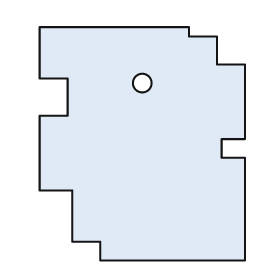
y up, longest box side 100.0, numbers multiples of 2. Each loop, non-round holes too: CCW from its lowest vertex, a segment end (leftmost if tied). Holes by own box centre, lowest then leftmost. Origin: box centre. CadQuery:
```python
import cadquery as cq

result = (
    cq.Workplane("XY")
    .moveTo(-18.0, -50.0)
    .lineTo(44.0, -50.0)
    .lineTo(44.0, -6.0)
    .lineTo(34.0, -6.0)
    .lineTo(34.0, 2.0)
    .lineTo(44.0, 2.0)
    .lineTo(44.0, 34.0)
    .lineTo(32.0, 34.0)
    .lineTo(32.0, 46.0)
    .lineTo(20.0, 46.0)
    .lineTo(20.0, 50.0)
    .lineTo(-44.0, 50.0)
    .lineTo(-44.0, 28.0)
    .lineTo(-32.0, 28.0)
    .lineTo(-32.0, 12.0)
    .lineTo(-44.0, 12.0)
    .lineTo(-44.0, -20.0)
    .lineTo(-30.0, -20.0)
    .lineTo(-30.0, -42.0)
    .lineTo(-18.0, -42.0)
    .close()
    .moveTo(0.0, 26.0)
    .circle(4.0)
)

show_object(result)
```